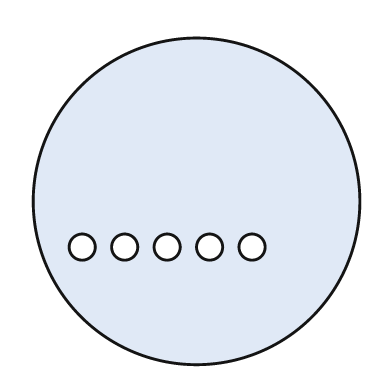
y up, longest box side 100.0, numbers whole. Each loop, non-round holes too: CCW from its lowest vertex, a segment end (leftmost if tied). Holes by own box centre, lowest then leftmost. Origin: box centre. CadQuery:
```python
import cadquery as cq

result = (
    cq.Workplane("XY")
    .moveTo(0.0, 0.0)
    .circle(50.0)
    .moveTo(-35.0, -14.0)
    .circle(4.0)
    .moveTo(-22.0, -14.0)
    .circle(4.0)
    .moveTo(-9.0, -14.0)
    .circle(4.0)
    .moveTo(4.0, -14.0)
    .circle(4.0)
    .moveTo(17.0, -14.0)
    .circle(4.0)
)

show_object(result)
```